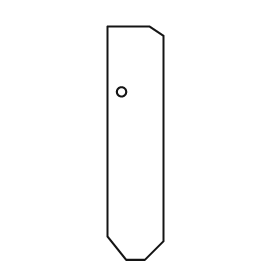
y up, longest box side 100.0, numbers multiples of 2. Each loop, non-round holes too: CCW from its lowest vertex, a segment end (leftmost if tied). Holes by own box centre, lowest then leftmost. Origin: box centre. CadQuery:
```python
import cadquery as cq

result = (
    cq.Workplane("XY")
    .moveTo(-4.0, -50.0)
    .lineTo(4.0, -50.0)
    .lineTo(12.0, -42.0)
    .lineTo(12.0, 46.0)
    .lineTo(6.0, 50.0)
    .lineTo(-12.0, 50.0)
    .lineTo(-12.0, -40.0)
    .close()
    .moveTo(-6.0, 22.0)
    .circle(2.0)
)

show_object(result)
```